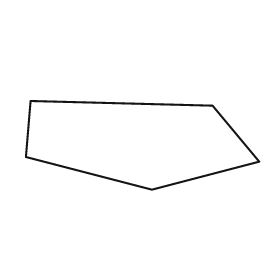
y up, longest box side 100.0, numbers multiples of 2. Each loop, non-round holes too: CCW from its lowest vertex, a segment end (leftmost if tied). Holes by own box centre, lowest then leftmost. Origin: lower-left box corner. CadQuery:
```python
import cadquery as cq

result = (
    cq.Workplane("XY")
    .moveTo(54.0, 0.0)
    .lineTo(100.0, 12.0)
    .lineTo(80.0, 36.0)
    .lineTo(2.0, 38.0)
    .lineTo(0.0, 14.0)
    .close()
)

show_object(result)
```